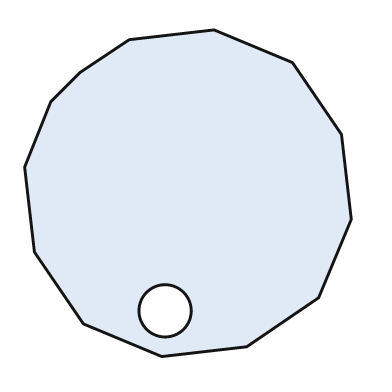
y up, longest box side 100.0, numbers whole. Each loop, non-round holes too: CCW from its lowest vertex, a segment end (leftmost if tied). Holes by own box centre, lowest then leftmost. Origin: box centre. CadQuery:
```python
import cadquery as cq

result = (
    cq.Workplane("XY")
    .moveTo(-8.0, -50.0)
    .lineTo(18.0, -47.0)
    .lineTo(40.0, -32.0)
    .lineTo(50.0, -8.0)
    .lineTo(47.0, 18.0)
    .lineTo(32.0, 40.0)
    .lineTo(8.0, 50.0)
    .lineTo(-18.0, 47.0)
    .lineTo(-33.0, 37.0)
    .lineTo(-42.0, 28.0)
    .lineTo(-50.0, 8.0)
    .lineTo(-47.0, -18.0)
    .lineTo(-32.0, -40.0)
    .close()
    .moveTo(-7.0, -36.0)
    .circle(8.0)
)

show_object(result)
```